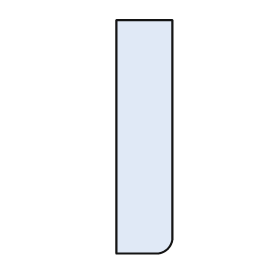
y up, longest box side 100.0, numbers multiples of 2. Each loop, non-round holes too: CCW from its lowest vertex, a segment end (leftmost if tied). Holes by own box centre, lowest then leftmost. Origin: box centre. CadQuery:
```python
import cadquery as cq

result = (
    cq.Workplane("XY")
    .moveTo(-12.0, -50.0)
    .lineTo(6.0, -50.0)
    .threePointArc((10.0, -48.0), (12.0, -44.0))
    .lineTo(12.0, 50.0)
    .lineTo(-12.0, 50.0)
    .close()
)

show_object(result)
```